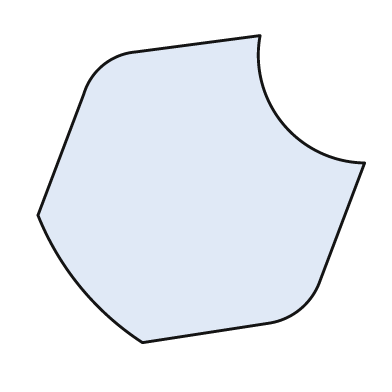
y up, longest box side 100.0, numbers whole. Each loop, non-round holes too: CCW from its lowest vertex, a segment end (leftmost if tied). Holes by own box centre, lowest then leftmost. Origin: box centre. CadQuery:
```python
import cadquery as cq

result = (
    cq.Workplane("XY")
    .moveTo(-18.0, -47.0)
    .lineTo(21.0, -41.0)
    .threePointArc((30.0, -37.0), (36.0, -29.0))
    .lineTo(50.0, 8.0)
    .threePointArc((25.0, 20.0), (18.0, 47.0))
    .lineTo(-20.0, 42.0)
    .threePointArc((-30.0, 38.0), (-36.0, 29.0))
    .lineTo(-50.0, -8.0)
    .threePointArc((-37.0, -30.0), (-18.0, -47.0))
    .close()
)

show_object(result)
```